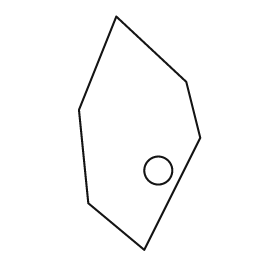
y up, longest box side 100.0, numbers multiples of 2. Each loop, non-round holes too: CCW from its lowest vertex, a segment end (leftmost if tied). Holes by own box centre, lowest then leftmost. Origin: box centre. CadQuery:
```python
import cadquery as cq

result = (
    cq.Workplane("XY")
    .moveTo(2.0, -50.0)
    .lineTo(26.0, -2.0)
    .lineTo(20.0, 22.0)
    .lineTo(-10.0, 50.0)
    .lineTo(-26.0, 10.0)
    .lineTo(-22.0, -30.0)
    .close()
    .moveTo(8.0, -16.0)
    .circle(6.0)
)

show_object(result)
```